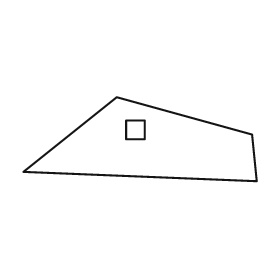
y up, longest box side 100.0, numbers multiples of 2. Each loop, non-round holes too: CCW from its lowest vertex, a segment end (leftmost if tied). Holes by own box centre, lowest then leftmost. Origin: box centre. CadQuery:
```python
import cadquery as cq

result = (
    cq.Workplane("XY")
    .moveTo(50.0, -18.0)
    .lineTo(48.0, 2.0)
    .lineTo(-10.0, 18.0)
    .lineTo(-50.0, -14.0)
    .close()
    .moveTo(-6.0, 0.0)
    .lineTo(2.0, 0.0)
    .lineTo(2.0, 8.0)
    .lineTo(-6.0, 8.0)
    .close()
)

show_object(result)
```